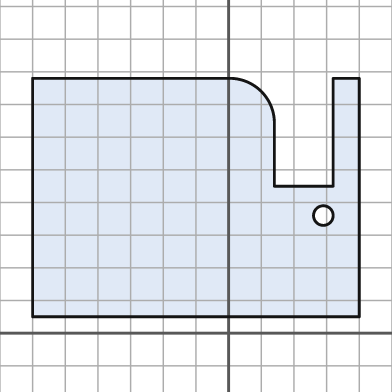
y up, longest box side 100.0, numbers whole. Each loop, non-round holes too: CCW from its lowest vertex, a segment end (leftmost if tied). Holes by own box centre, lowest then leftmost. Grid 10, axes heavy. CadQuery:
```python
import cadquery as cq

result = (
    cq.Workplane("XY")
    .moveTo(-60.0, 5.0)
    .lineTo(40.0, 5.0)
    .lineTo(40.0, 78.0)
    .lineTo(32.0, 78.0)
    .lineTo(32.0, 45.0)
    .lineTo(14.0, 45.0)
    .lineTo(14.0, 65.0)
    .threePointArc((10.0, 74.0), (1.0, 78.0))
    .lineTo(-60.0, 78.0)
    .close()
    .moveTo(29.0, 36.0)
    .circle(3.0)
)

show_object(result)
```